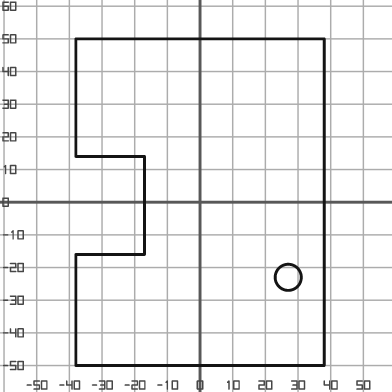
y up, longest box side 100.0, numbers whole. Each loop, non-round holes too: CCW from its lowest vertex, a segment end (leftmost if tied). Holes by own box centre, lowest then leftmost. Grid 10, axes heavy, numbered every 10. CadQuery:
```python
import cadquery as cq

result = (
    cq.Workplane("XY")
    .moveTo(-38.0, -50.0)
    .lineTo(38.0, -50.0)
    .lineTo(38.0, 50.0)
    .lineTo(-38.0, 50.0)
    .lineTo(-38.0, 14.0)
    .lineTo(-17.0, 14.0)
    .lineTo(-17.0, -16.0)
    .lineTo(-38.0, -16.0)
    .close()
    .moveTo(27.0, -23.0)
    .circle(4.0)
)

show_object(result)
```